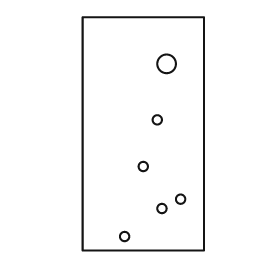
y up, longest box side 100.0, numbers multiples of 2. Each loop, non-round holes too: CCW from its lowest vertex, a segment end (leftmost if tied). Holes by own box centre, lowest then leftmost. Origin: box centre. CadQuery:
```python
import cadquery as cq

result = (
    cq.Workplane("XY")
    .moveTo(-26.0, -50.0)
    .lineTo(26.0, -50.0)
    .lineTo(26.0, 50.0)
    .lineTo(-26.0, 50.0)
    .close()
    .moveTo(-8.0, -44.0)
    .circle(2.0)
    .moveTo(8.0, -32.0)
    .circle(2.0)
    .moveTo(16.0, -28.0)
    .circle(2.0)
    .moveTo(0.0, -14.0)
    .circle(2.0)
    .moveTo(6.0, 6.0)
    .circle(2.0)
    .moveTo(10.0, 30.0)
    .circle(4.0)
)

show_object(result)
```